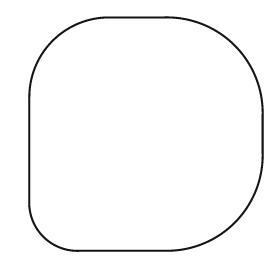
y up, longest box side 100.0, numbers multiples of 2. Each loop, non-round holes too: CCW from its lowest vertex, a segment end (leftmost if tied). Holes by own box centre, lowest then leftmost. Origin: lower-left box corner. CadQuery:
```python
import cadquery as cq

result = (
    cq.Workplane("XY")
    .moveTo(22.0, 0.0)
    .lineTo(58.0, 0.0)
    .threePointArc((88.0, 12.0), (100.0, 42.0))
    .lineTo(100.0, 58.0)
    .threePointArc((88.0, 88.0), (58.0, 100.0))
    .lineTo(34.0, 100.0)
    .threePointArc((10.0, 90.0), (0.0, 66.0))
    .lineTo(0.0, 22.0)
    .threePointArc((6.0, 6.0), (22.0, 0.0))
    .close()
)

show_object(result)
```